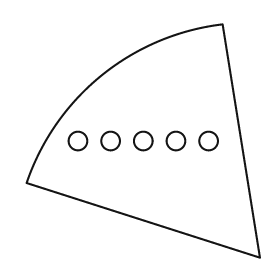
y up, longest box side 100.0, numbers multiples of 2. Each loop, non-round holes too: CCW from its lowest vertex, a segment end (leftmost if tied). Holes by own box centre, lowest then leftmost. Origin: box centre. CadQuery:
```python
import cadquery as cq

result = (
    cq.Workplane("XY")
    .moveTo(50.0, -50.0)
    .lineTo(34.0, 50.0)
    .threePointArc((-18.0, 28.0), (-50.0, -18.0))
    .close()
    .moveTo(-28.0, 0.0)
    .circle(4.0)
    .moveTo(-14.0, 0.0)
    .circle(4.0)
    .moveTo(0.0, 0.0)
    .circle(4.0)
    .moveTo(14.0, 0.0)
    .circle(4.0)
    .moveTo(28.0, 0.0)
    .circle(4.0)
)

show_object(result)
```